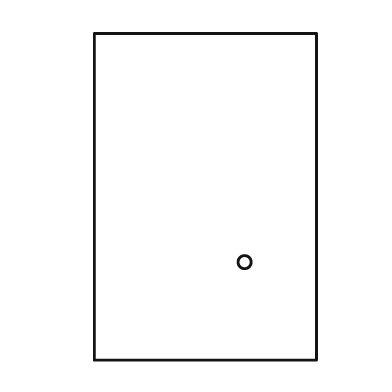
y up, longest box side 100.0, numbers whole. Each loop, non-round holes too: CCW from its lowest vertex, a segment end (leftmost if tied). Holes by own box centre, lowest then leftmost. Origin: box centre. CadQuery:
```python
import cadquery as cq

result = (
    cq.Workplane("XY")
    .moveTo(-34.0, -50.0)
    .lineTo(34.0, -50.0)
    .lineTo(34.0, 50.0)
    .lineTo(-34.0, 50.0)
    .close()
    .moveTo(12.0, -20.0)
    .circle(2.0)
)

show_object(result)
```